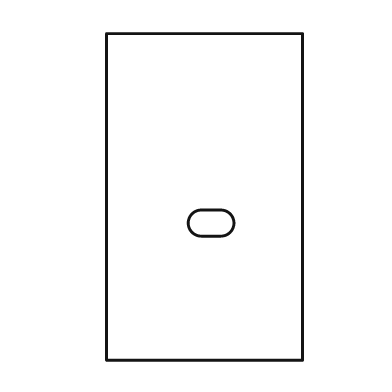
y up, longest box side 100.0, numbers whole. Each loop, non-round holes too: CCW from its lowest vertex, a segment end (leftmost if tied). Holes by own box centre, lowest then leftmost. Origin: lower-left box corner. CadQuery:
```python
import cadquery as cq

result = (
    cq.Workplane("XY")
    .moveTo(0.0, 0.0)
    .lineTo(60.0, 0.0)
    .lineTo(60.0, 100.0)
    .lineTo(0.0, 100.0)
    .close()
    .moveTo(29.0, 38.0)
    .lineTo(35.0, 38.0)
    .threePointArc((39.0, 42.0), (35.0, 46.0))
    .lineTo(29.0, 46.0)
    .threePointArc((25.0, 42.0), (29.0, 38.0))
    .close()
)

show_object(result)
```